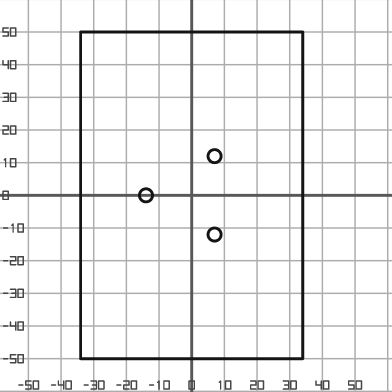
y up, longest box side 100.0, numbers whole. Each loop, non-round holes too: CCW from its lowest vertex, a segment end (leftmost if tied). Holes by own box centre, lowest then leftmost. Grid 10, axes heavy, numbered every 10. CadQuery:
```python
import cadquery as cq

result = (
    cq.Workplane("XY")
    .moveTo(-34.0, -50.0)
    .lineTo(34.0, -50.0)
    .lineTo(34.0, 50.0)
    .lineTo(-34.0, 50.0)
    .close()
    .moveTo(7.0, -12.0)
    .circle(2.0)
    .moveTo(-14.0, 0.0)
    .circle(2.0)
    .moveTo(7.0, 12.0)
    .circle(2.0)
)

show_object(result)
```